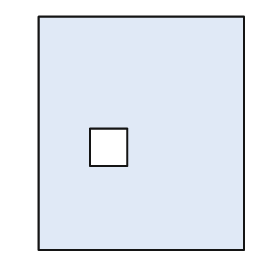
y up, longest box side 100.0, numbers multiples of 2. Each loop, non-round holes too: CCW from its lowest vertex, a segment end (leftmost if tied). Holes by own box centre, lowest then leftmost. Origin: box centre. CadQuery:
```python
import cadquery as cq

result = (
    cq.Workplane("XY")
    .moveTo(-44.0, -50.0)
    .lineTo(44.0, -50.0)
    .lineTo(44.0, 50.0)
    .lineTo(-44.0, 50.0)
    .close()
    .moveTo(-22.0, -14.0)
    .lineTo(-6.0, -14.0)
    .lineTo(-6.0, 2.0)
    .lineTo(-22.0, 2.0)
    .close()
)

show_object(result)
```